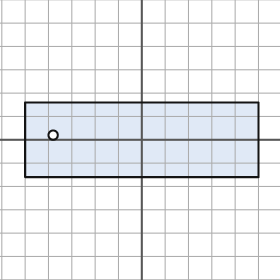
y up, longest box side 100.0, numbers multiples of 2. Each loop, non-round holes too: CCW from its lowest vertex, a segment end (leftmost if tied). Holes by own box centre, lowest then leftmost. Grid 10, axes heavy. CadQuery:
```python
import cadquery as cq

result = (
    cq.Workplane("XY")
    .moveTo(-50.0, -16.0)
    .lineTo(50.0, -16.0)
    .lineTo(50.0, 16.0)
    .lineTo(-50.0, 16.0)
    .close()
    .moveTo(-38.0, 2.0)
    .circle(2.0)
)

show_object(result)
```